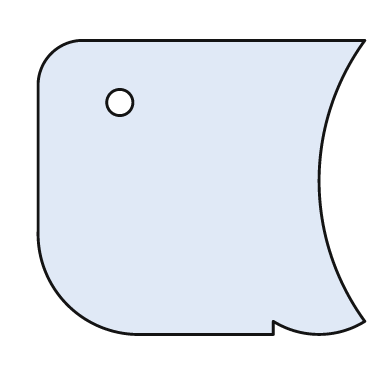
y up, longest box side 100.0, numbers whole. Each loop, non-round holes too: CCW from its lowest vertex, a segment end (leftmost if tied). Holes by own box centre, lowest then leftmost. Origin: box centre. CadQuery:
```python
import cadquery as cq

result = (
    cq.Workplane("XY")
    .moveTo(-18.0, -45.0)
    .lineTo(22.0, -45.0)
    .lineTo(22.0, -41.0)
    .threePointArc((36.0, -45.0), (50.0, -41.0))
    .threePointArc((36.0, 2.0), (50.0, 45.0))
    .lineTo(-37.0, 45.0)
    .threePointArc((-46.0, 41.0), (-50.0, 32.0))
    .lineTo(-50.0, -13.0)
    .threePointArc((-41.0, -36.0), (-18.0, -45.0))
    .close()
    .moveTo(-25.0, 26.0)
    .circle(4.0)
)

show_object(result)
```